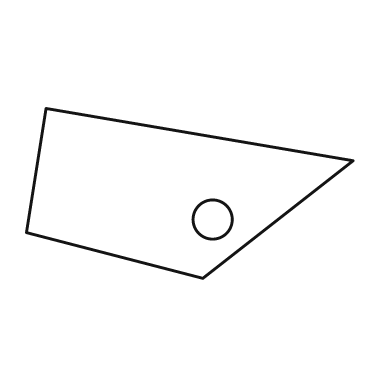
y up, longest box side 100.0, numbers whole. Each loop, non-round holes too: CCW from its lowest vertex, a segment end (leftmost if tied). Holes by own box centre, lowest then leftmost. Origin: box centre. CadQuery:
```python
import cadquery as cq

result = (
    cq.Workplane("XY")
    .moveTo(4.0, -26.0)
    .lineTo(50.0, 10.0)
    .lineTo(-44.0, 26.0)
    .lineTo(-50.0, -12.0)
    .close()
    .moveTo(7.0, -8.0)
    .circle(6.0)
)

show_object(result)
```